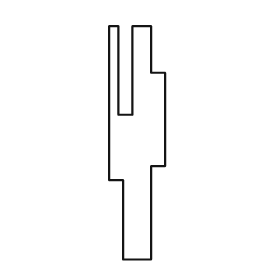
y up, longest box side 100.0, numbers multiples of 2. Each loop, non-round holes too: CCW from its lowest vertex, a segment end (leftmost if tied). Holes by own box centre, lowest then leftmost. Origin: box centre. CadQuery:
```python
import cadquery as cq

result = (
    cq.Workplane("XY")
    .moveTo(-6.0, -50.0)
    .lineTo(6.0, -50.0)
    .lineTo(6.0, -10.0)
    .lineTo(12.0, -10.0)
    .lineTo(12.0, 30.0)
    .lineTo(6.0, 30.0)
    .lineTo(6.0, 50.0)
    .lineTo(-2.0, 50.0)
    .lineTo(-2.0, 12.0)
    .lineTo(-8.0, 12.0)
    .lineTo(-8.0, 50.0)
    .lineTo(-12.0, 50.0)
    .lineTo(-12.0, -16.0)
    .lineTo(-6.0, -16.0)
    .close()
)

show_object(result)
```